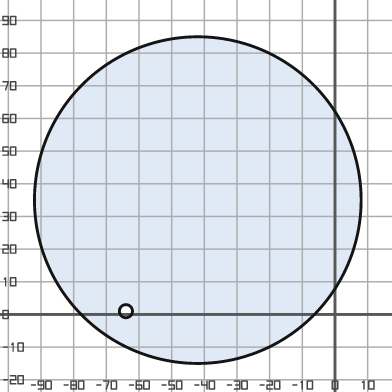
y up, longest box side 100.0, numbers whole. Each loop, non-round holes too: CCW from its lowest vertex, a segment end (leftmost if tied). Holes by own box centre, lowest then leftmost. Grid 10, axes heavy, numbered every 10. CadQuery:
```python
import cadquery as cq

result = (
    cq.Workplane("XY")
    .moveTo(-42.0, 35.0)
    .circle(50.0)
    .moveTo(-64.0, 1.0)
    .circle(2.0)
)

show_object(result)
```